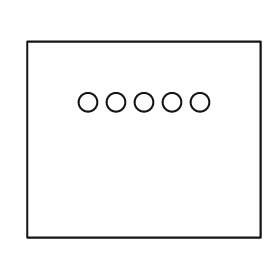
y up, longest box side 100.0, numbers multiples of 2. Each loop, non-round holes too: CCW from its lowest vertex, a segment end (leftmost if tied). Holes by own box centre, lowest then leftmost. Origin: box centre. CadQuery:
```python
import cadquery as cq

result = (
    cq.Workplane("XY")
    .moveTo(-50.0, -42.0)
    .lineTo(50.0, -42.0)
    .lineTo(50.0, 42.0)
    .lineTo(-50.0, 42.0)
    .close()
    .moveTo(-24.0, 16.0)
    .circle(4.0)
    .moveTo(-12.0, 16.0)
    .circle(4.0)
    .moveTo(0.0, 16.0)
    .circle(4.0)
    .moveTo(12.0, 16.0)
    .circle(4.0)
    .moveTo(24.0, 16.0)
    .circle(4.0)
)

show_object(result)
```